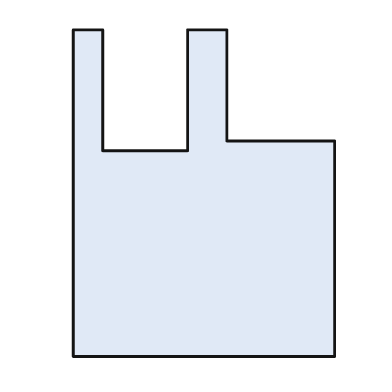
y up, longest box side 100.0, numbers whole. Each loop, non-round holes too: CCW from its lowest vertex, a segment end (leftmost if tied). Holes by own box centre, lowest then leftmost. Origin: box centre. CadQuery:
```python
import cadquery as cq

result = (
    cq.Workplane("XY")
    .moveTo(-40.0, -50.0)
    .lineTo(40.0, -50.0)
    .lineTo(40.0, 16.0)
    .lineTo(7.0, 16.0)
    .lineTo(7.0, 50.0)
    .lineTo(-5.0, 50.0)
    .lineTo(-5.0, 13.0)
    .lineTo(-31.0, 13.0)
    .lineTo(-31.0, 50.0)
    .lineTo(-40.0, 50.0)
    .close()
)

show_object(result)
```